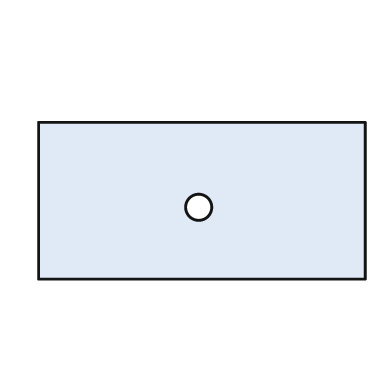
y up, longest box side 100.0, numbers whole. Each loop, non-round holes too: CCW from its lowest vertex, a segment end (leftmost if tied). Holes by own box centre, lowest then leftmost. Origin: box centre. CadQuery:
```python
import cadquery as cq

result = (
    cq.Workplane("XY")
    .moveTo(-50.0, -24.0)
    .lineTo(50.0, -24.0)
    .lineTo(50.0, 24.0)
    .lineTo(-50.0, 24.0)
    .close()
    .moveTo(-1.0, -2.0)
    .circle(4.0)
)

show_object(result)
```